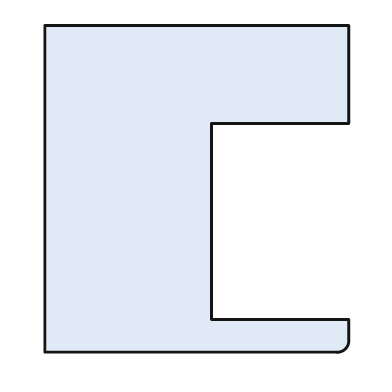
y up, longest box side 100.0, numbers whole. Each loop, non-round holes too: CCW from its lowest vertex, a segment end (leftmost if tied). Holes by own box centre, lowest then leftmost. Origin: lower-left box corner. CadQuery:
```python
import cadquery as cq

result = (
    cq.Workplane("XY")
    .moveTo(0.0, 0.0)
    .lineTo(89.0, 0.0)
    .threePointArc((92.0, 1.0), (93.0, 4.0))
    .lineTo(93.0, 10.0)
    .lineTo(51.0, 10.0)
    .lineTo(51.0, 70.0)
    .lineTo(93.0, 70.0)
    .lineTo(93.0, 100.0)
    .lineTo(0.0, 100.0)
    .close()
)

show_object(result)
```